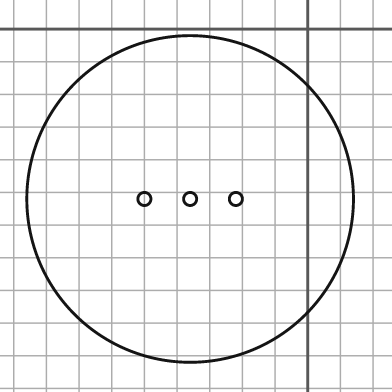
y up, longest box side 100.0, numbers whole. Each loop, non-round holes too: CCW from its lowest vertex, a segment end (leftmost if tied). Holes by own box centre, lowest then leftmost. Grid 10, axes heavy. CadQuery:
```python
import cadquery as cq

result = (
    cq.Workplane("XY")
    .moveTo(-36.0, -52.0)
    .circle(50.0)
    .moveTo(-50.0, -52.0)
    .circle(2.0)
    .moveTo(-36.0, -52.0)
    .circle(2.0)
    .moveTo(-22.0, -52.0)
    .circle(2.0)
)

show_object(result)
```